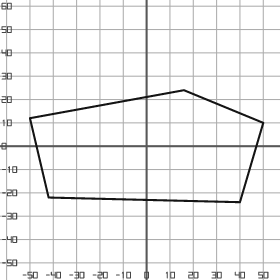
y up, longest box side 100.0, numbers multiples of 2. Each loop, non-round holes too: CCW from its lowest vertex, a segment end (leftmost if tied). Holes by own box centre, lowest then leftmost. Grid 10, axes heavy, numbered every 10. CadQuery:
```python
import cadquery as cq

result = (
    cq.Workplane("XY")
    .moveTo(40.0, -24.0)
    .lineTo(50.0, 10.0)
    .lineTo(16.0, 24.0)
    .lineTo(-50.0, 12.0)
    .lineTo(-42.0, -22.0)
    .close()
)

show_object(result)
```